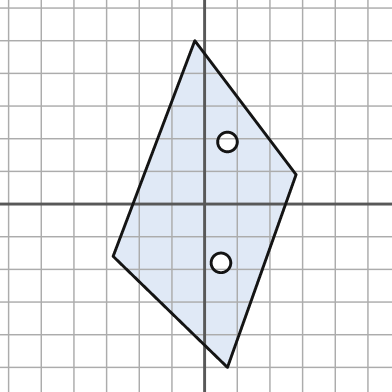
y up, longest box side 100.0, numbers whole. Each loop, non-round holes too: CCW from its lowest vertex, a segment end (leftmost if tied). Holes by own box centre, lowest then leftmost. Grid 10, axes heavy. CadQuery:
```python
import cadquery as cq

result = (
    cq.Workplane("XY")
    .moveTo(7.0, -50.0)
    .lineTo(28.0, 9.0)
    .lineTo(-3.0, 50.0)
    .lineTo(-28.0, -16.0)
    .close()
    .moveTo(5.0, -18.0)
    .circle(3.0)
    .moveTo(7.0, 19.0)
    .circle(3.0)
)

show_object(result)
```